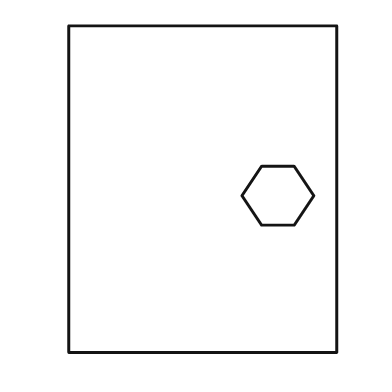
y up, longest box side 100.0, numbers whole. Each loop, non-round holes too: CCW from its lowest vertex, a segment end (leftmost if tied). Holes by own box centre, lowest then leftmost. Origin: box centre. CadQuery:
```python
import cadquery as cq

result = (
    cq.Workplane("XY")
    .moveTo(-41.0, -50.0)
    .lineTo(41.0, -50.0)
    .lineTo(41.0, 50.0)
    .lineTo(-41.0, 50.0)
    .close()
    .moveTo(18.0, -11.0)
    .lineTo(28.0, -11.0)
    .lineTo(34.0, -2.0)
    .lineTo(28.0, 7.0)
    .lineTo(18.0, 7.0)
    .lineTo(12.0, -2.0)
    .close()
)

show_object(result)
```